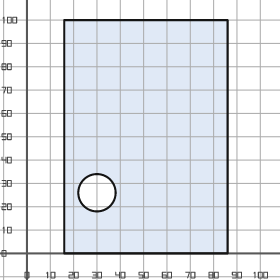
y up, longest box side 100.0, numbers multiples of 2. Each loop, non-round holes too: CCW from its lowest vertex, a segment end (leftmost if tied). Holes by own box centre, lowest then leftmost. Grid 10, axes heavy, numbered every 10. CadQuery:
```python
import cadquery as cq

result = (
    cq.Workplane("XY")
    .moveTo(16.0, 0.0)
    .lineTo(86.0, 0.0)
    .lineTo(86.0, 100.0)
    .lineTo(16.0, 100.0)
    .close()
    .moveTo(30.0, 26.0)
    .circle(8.0)
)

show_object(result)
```